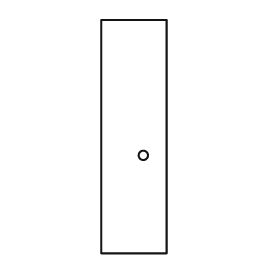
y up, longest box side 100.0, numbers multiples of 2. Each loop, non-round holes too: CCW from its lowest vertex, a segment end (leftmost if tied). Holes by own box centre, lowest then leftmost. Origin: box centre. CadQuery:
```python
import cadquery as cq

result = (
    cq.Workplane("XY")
    .moveTo(-14.0, -50.0)
    .lineTo(14.0, -50.0)
    .lineTo(14.0, 50.0)
    .lineTo(-14.0, 50.0)
    .close()
    .moveTo(4.0, -8.0)
    .circle(2.0)
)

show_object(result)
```